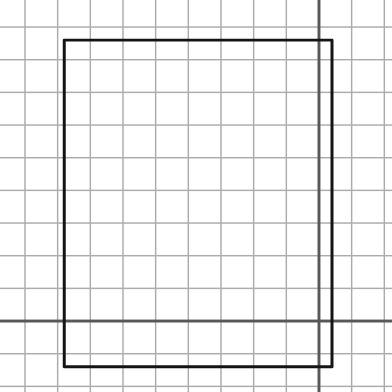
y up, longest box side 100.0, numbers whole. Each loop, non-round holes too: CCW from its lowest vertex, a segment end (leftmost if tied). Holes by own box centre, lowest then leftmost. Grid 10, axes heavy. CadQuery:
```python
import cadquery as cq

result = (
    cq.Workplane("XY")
    .moveTo(-78.0, -14.0)
    .lineTo(4.0, -14.0)
    .lineTo(4.0, 86.0)
    .lineTo(-78.0, 86.0)
    .close()
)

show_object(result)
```